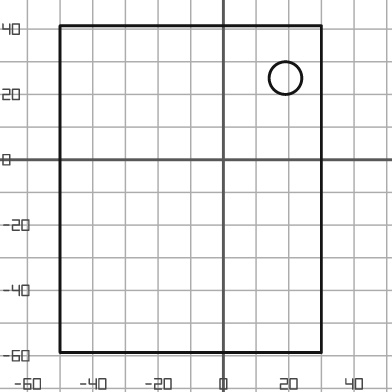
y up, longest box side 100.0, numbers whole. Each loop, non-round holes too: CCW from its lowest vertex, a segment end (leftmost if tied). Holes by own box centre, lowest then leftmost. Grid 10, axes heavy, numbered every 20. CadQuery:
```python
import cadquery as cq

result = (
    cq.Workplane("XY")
    .moveTo(-50.0, -59.0)
    .lineTo(30.0, -59.0)
    .lineTo(30.0, 41.0)
    .lineTo(-50.0, 41.0)
    .close()
    .moveTo(19.0, 25.0)
    .circle(5.0)
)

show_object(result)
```